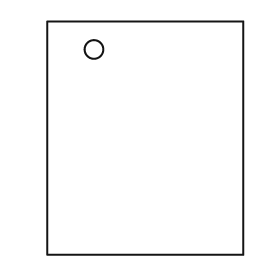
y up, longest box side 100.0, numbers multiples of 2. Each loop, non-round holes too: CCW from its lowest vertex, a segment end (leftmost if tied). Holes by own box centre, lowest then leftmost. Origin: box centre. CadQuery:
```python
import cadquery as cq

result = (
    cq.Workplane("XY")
    .moveTo(-42.0, -50.0)
    .lineTo(42.0, -50.0)
    .lineTo(42.0, 50.0)
    .lineTo(-42.0, 50.0)
    .close()
    .moveTo(-22.0, 38.0)
    .circle(4.0)
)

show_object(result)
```